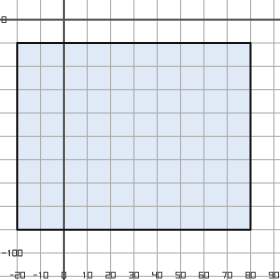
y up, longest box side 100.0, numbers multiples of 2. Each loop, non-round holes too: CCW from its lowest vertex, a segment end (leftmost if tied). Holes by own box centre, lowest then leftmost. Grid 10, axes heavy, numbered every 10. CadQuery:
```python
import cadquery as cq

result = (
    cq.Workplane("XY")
    .moveTo(-20.0, -90.0)
    .lineTo(80.0, -90.0)
    .lineTo(80.0, -10.0)
    .lineTo(-20.0, -10.0)
    .close()
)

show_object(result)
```